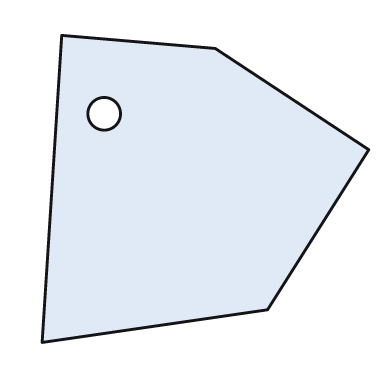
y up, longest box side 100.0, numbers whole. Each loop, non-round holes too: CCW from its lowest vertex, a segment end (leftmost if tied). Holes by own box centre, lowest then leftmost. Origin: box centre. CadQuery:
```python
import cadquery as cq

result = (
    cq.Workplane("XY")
    .moveTo(-50.0, -47.0)
    .lineTo(19.0, -37.0)
    .lineTo(50.0, 12.0)
    .lineTo(3.0, 43.0)
    .lineTo(-44.0, 47.0)
    .close()
    .moveTo(-31.0, 23.0)
    .circle(5.0)
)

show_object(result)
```